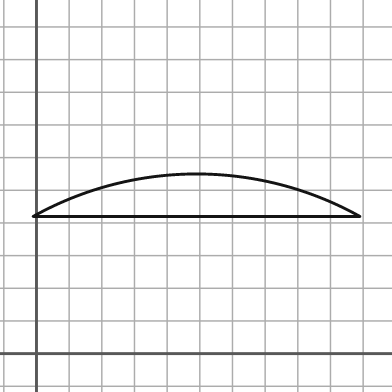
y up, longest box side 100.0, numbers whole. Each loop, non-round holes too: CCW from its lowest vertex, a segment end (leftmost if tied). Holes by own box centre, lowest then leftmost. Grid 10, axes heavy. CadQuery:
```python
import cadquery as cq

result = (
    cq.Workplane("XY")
    .moveTo(-1.0, 42.0)
    .lineTo(99.0, 42.0)
    .threePointArc((49.0, 55.0), (-1.0, 42.0))
    .close()
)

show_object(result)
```